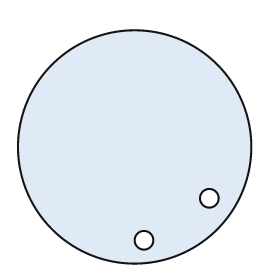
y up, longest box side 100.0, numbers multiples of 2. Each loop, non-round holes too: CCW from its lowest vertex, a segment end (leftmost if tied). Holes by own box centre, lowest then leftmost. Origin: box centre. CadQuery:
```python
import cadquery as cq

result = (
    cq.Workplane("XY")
    .moveTo(0.0, 0.0)
    .circle(50.0)
    .moveTo(4.0, -40.0)
    .circle(4.0)
    .moveTo(32.0, -22.0)
    .circle(4.0)
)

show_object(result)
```